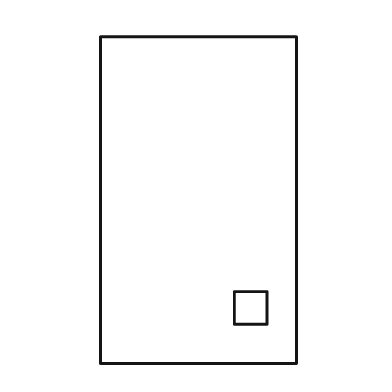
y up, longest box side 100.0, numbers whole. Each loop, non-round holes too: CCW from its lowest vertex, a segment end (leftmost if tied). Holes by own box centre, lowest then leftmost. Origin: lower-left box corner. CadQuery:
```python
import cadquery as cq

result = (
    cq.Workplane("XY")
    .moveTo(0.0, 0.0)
    .lineTo(60.0, 0.0)
    .lineTo(60.0, 100.0)
    .lineTo(0.0, 100.0)
    .close()
    .moveTo(41.0, 12.0)
    .lineTo(51.0, 12.0)
    .lineTo(51.0, 22.0)
    .lineTo(41.0, 22.0)
    .close()
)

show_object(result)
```